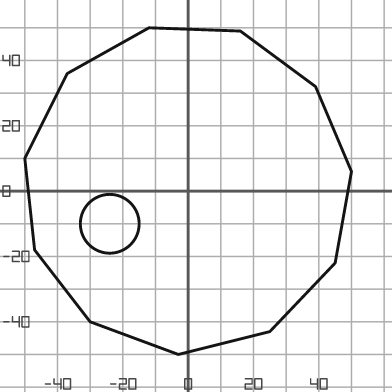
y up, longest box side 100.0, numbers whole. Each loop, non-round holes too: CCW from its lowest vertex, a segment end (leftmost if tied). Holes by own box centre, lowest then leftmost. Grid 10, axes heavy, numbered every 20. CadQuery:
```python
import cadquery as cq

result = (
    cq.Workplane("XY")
    .moveTo(-3.0, -50.0)
    .lineTo(25.0, -43.0)
    .lineTo(45.0, -22.0)
    .lineTo(50.0, 6.0)
    .lineTo(39.0, 32.0)
    .lineTo(16.0, 49.0)
    .lineTo(-12.0, 50.0)
    .lineTo(-37.0, 36.0)
    .lineTo(-50.0, 10.0)
    .lineTo(-47.0, -18.0)
    .lineTo(-30.0, -40.0)
    .close()
    .moveTo(-24.0, -10.0)
    .circle(9.0)
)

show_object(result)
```